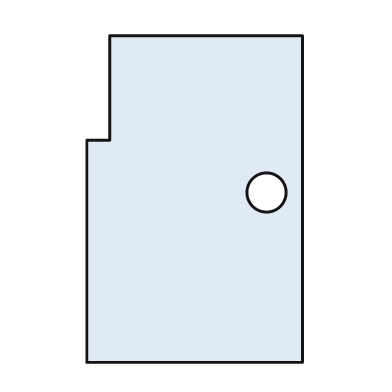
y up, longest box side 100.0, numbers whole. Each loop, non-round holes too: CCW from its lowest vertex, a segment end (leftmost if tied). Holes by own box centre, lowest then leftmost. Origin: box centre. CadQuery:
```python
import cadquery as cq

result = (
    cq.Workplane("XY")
    .moveTo(-33.0, -50.0)
    .lineTo(33.0, -50.0)
    .lineTo(33.0, 50.0)
    .lineTo(-26.0, 50.0)
    .lineTo(-26.0, 18.0)
    .lineTo(-33.0, 18.0)
    .close()
    .moveTo(22.0, 2.0)
    .circle(6.0)
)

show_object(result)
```